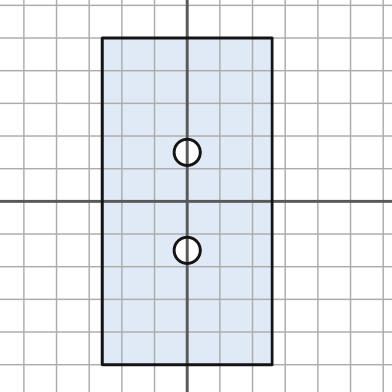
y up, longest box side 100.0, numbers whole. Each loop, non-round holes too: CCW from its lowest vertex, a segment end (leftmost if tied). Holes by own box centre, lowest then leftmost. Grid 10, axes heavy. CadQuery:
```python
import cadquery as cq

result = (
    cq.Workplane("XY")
    .moveTo(-26.0, -50.0)
    .lineTo(26.0, -50.0)
    .lineTo(26.0, 50.0)
    .lineTo(-26.0, 50.0)
    .close()
    .moveTo(0.0, -15.0)
    .circle(4.0)
    .moveTo(0.0, 15.0)
    .circle(4.0)
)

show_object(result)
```